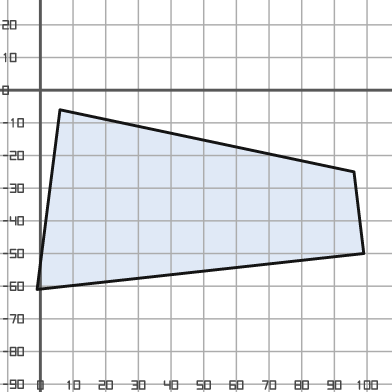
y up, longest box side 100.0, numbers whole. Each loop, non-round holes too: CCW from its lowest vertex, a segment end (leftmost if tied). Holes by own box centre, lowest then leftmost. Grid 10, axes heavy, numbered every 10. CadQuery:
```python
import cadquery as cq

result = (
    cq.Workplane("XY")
    .moveTo(-1.0, -61.0)
    .lineTo(99.0, -50.0)
    .lineTo(96.0, -25.0)
    .lineTo(6.0, -6.0)
    .close()
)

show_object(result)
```